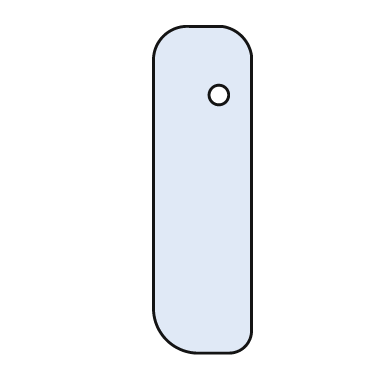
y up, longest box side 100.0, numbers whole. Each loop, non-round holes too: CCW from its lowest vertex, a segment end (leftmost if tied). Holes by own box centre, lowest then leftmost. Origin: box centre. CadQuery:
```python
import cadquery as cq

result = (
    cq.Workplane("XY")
    .moveTo(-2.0, -50.0)
    .lineTo(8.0, -50.0)
    .threePointArc((13.0, -48.0), (15.0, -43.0))
    .lineTo(15.0, 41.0)
    .threePointArc((12.0, 47.0), (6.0, 50.0))
    .lineTo(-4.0, 50.0)
    .threePointArc((-12.0, 47.0), (-15.0, 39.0))
    .lineTo(-15.0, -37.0)
    .threePointArc((-11.0, -46.0), (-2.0, -50.0))
    .close()
    .moveTo(5.0, 29.0)
    .circle(3.0)
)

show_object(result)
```